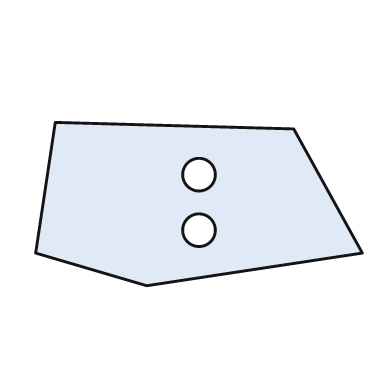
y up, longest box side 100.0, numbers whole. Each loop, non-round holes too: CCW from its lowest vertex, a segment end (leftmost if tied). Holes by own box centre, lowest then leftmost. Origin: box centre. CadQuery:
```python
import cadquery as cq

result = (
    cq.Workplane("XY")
    .moveTo(-16.0, -25.0)
    .lineTo(50.0, -15.0)
    .lineTo(29.0, 23.0)
    .lineTo(-44.0, 25.0)
    .lineTo(-50.0, -15.0)
    .close()
    .moveTo(0.0, -8.0)
    .circle(5.0)
    .moveTo(0.0, 9.0)
    .circle(5.0)
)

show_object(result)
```